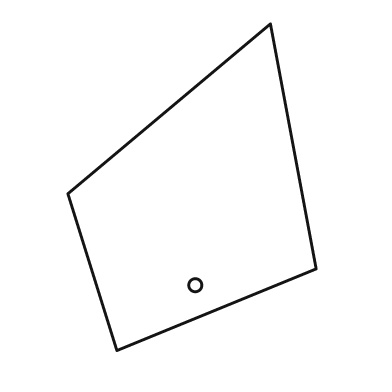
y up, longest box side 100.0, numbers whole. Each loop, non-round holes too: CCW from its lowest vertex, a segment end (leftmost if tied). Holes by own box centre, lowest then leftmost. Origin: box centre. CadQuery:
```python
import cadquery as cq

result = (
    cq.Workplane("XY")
    .moveTo(-23.0, -50.0)
    .lineTo(38.0, -25.0)
    .lineTo(24.0, 50.0)
    .lineTo(-38.0, -2.0)
    .close()
    .moveTo(1.0, -30.0)
    .circle(2.0)
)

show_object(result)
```